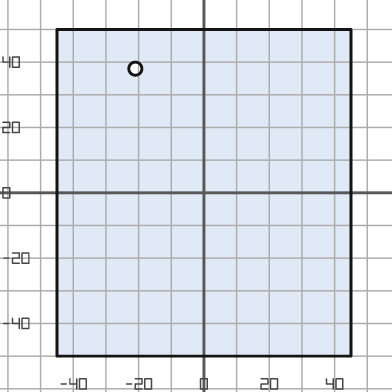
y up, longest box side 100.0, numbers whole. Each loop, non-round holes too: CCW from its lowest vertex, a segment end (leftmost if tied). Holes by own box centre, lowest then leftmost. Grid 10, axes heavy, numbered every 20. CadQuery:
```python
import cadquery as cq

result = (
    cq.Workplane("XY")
    .moveTo(-45.0, -50.0)
    .lineTo(45.0, -50.0)
    .lineTo(45.0, 50.0)
    .lineTo(-45.0, 50.0)
    .close()
    .moveTo(-21.0, 38.0)
    .circle(2.0)
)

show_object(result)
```